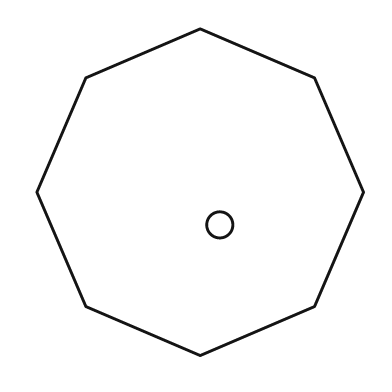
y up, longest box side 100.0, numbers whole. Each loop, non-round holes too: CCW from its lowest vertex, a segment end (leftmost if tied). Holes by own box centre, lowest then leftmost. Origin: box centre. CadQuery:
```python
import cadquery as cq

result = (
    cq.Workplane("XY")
    .moveTo(0.0, -50.0)
    .lineTo(35.0, -35.0)
    .lineTo(50.0, 0.0)
    .lineTo(35.0, 35.0)
    .lineTo(0.0, 50.0)
    .lineTo(-35.0, 35.0)
    .lineTo(-50.0, 0.0)
    .lineTo(-35.0, -35.0)
    .close()
    .moveTo(6.0, -10.0)
    .circle(4.0)
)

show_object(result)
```